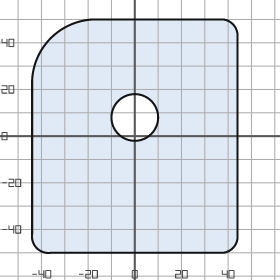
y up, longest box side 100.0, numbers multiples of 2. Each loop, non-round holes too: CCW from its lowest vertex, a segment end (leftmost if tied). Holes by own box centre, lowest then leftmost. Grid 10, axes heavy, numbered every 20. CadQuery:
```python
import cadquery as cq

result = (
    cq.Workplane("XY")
    .moveTo(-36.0, -50.0)
    .lineTo(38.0, -50.0)
    .threePointArc((42.0, -48.0), (44.0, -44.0))
    .lineTo(44.0, 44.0)
    .threePointArc((42.0, 48.0), (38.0, 50.0))
    .lineTo(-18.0, 50.0)
    .threePointArc((-36.0, 42.0), (-44.0, 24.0))
    .lineTo(-44.0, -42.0)
    .threePointArc((-42.0, -48.0), (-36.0, -50.0))
    .close()
    .moveTo(0.0, 8.0)
    .circle(10.0)
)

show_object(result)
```